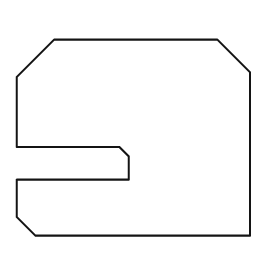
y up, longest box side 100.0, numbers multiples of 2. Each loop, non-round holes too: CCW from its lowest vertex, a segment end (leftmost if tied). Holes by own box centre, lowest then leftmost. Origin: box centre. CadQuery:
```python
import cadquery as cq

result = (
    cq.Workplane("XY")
    .moveTo(-42.0, -42.0)
    .lineTo(50.0, -42.0)
    .lineTo(50.0, 28.0)
    .lineTo(36.0, 42.0)
    .lineTo(-34.0, 42.0)
    .lineTo(-50.0, 26.0)
    .lineTo(-50.0, -4.0)
    .lineTo(-6.0, -4.0)
    .lineTo(-2.0, -8.0)
    .lineTo(-2.0, -18.0)
    .lineTo(-50.0, -18.0)
    .lineTo(-50.0, -34.0)
    .close()
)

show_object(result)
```